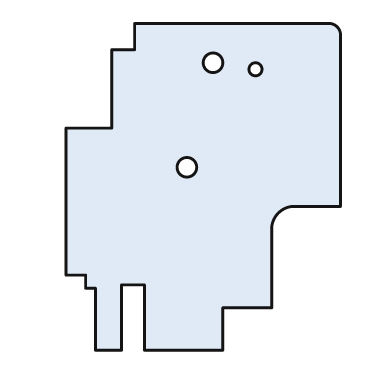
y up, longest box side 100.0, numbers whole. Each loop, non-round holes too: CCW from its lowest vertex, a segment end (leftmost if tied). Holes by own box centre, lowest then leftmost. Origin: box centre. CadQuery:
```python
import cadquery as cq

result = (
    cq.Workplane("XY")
    .moveTo(-33.0, -50.0)
    .lineTo(-25.0, -50.0)
    .lineTo(-25.0, -30.0)
    .lineTo(-18.0, -30.0)
    .lineTo(-18.0, -50.0)
    .lineTo(6.0, -50.0)
    .lineTo(6.0, -37.0)
    .lineTo(21.0, -37.0)
    .lineTo(21.0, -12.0)
    .threePointArc((23.0, -8.0), (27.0, -6.0))
    .lineTo(42.0, -6.0)
    .lineTo(42.0, 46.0)
    .threePointArc((41.0, 49.0), (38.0, 50.0))
    .lineTo(-21.0, 50.0)
    .lineTo(-21.0, 42.0)
    .lineTo(-28.0, 42.0)
    .lineTo(-28.0, 18.0)
    .lineTo(-42.0, 18.0)
    .lineTo(-42.0, -27.0)
    .lineTo(-36.0, -27.0)
    .lineTo(-36.0, -31.0)
    .lineTo(-33.0, -31.0)
    .close()
    .moveTo(-5.0, 6.0)
    .circle(3.0)
    .moveTo(16.0, 36.0)
    .circle(2.0)
    .moveTo(3.0, 38.0)
    .circle(3.0)
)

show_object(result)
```